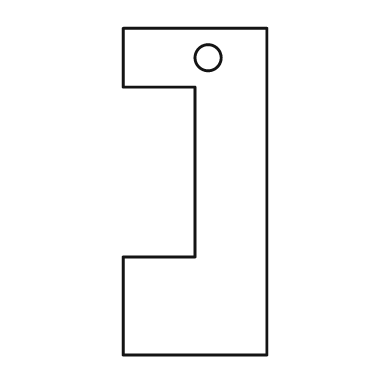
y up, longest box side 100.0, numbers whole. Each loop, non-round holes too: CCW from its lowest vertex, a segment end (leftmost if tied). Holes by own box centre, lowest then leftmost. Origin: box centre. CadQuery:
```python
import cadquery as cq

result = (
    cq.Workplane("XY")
    .moveTo(-22.0, -50.0)
    .lineTo(22.0, -50.0)
    .lineTo(22.0, 50.0)
    .lineTo(-22.0, 50.0)
    .lineTo(-22.0, 32.0)
    .lineTo(0.0, 32.0)
    .lineTo(0.0, -20.0)
    .lineTo(-22.0, -20.0)
    .close()
    .moveTo(4.0, 41.0)
    .circle(4.0)
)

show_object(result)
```